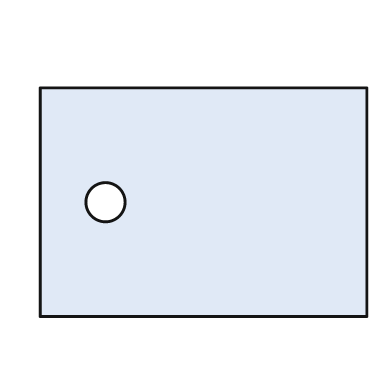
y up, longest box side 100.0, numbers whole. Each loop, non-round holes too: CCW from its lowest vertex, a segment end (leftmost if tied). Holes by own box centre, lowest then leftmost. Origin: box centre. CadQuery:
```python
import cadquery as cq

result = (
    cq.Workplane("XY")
    .moveTo(-50.0, -35.0)
    .lineTo(50.0, -35.0)
    .lineTo(50.0, 35.0)
    .lineTo(-50.0, 35.0)
    .close()
    .moveTo(-30.0, 0.0)
    .circle(6.0)
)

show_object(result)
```